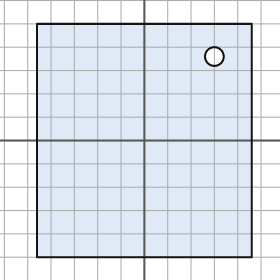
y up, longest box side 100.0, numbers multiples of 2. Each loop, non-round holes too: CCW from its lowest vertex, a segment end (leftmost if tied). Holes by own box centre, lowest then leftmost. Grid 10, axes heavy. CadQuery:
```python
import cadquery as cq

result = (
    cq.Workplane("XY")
    .moveTo(-46.0, -50.0)
    .lineTo(46.0, -50.0)
    .lineTo(46.0, 50.0)
    .lineTo(-46.0, 50.0)
    .close()
    .moveTo(30.0, 36.0)
    .circle(4.0)
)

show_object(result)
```